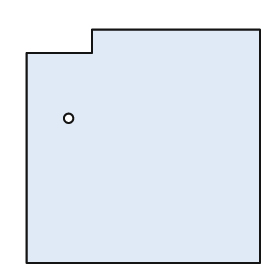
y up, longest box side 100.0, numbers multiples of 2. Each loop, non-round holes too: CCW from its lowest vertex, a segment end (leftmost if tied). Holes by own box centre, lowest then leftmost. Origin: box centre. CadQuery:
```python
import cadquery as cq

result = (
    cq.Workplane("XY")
    .moveTo(-50.0, -50.0)
    .lineTo(50.0, -50.0)
    .lineTo(50.0, 50.0)
    .lineTo(-22.0, 50.0)
    .lineTo(-22.0, 40.0)
    .lineTo(-50.0, 40.0)
    .close()
    .moveTo(-32.0, 12.0)
    .circle(2.0)
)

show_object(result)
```